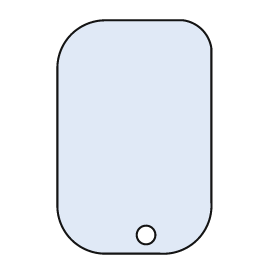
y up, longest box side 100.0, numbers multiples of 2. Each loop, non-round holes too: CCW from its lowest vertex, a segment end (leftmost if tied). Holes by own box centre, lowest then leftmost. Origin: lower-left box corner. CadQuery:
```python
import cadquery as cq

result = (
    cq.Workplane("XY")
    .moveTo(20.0, 0.0)
    .lineTo(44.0, 0.0)
    .threePointArc((60.0, 6.0), (66.0, 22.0))
    .lineTo(66.0, 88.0)
    .threePointArc((62.0, 96.0), (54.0, 100.0))
    .lineTo(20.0, 100.0)
    .threePointArc((6.0, 94.0), (0.0, 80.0))
    .lineTo(0.0, 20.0)
    .threePointArc((6.0, 6.0), (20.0, 0.0))
    .close()
    .moveTo(38.0, 8.0)
    .circle(4.0)
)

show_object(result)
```